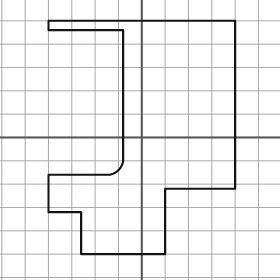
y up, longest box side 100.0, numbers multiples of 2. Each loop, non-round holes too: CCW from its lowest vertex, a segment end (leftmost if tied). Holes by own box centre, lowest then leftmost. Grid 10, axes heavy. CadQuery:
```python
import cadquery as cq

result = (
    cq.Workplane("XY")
    .moveTo(-26.0, -50.0)
    .lineTo(10.0, -50.0)
    .lineTo(10.0, -22.0)
    .lineTo(40.0, -22.0)
    .lineTo(40.0, 50.0)
    .lineTo(-40.0, 50.0)
    .lineTo(-40.0, 46.0)
    .lineTo(-8.0, 46.0)
    .lineTo(-8.0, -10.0)
    .threePointArc((-10.0, -14.0), (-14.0, -16.0))
    .lineTo(-40.0, -16.0)
    .lineTo(-40.0, -32.0)
    .lineTo(-26.0, -32.0)
    .close()
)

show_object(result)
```